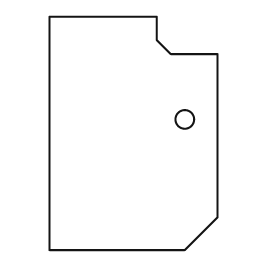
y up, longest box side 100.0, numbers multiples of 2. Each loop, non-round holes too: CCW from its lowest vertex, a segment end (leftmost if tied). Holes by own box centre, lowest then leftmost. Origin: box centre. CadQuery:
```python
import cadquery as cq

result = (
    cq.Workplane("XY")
    .moveTo(-36.0, -50.0)
    .lineTo(22.0, -50.0)
    .lineTo(36.0, -36.0)
    .lineTo(36.0, 34.0)
    .lineTo(16.0, 34.0)
    .lineTo(10.0, 40.0)
    .lineTo(10.0, 50.0)
    .lineTo(-36.0, 50.0)
    .close()
    .moveTo(22.0, 6.0)
    .circle(4.0)
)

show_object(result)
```